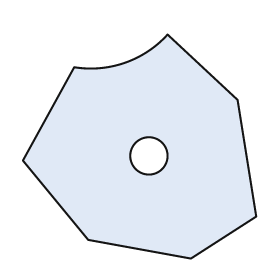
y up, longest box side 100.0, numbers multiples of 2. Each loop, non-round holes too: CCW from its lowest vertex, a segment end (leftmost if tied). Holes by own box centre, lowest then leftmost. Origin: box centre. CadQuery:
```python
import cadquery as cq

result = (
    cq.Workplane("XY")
    .moveTo(22.0, -48.0)
    .lineTo(50.0, -30.0)
    .lineTo(42.0, 20.0)
    .lineTo(12.0, 48.0)
    .threePointArc((-6.0, 36.0), (-28.0, 34.0))
    .lineTo(-50.0, -6.0)
    .lineTo(-22.0, -40.0)
    .close()
    .moveTo(4.0, -4.0)
    .circle(8.0)
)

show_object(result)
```